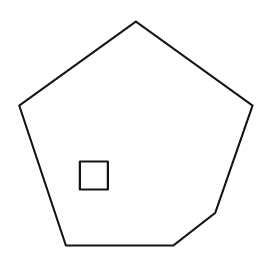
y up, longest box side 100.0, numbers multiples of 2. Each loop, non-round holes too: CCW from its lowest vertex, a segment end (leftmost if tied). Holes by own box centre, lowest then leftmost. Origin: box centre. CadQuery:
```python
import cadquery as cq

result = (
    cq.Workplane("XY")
    .moveTo(-30.0, -48.0)
    .lineTo(16.0, -48.0)
    .lineTo(34.0, -34.0)
    .lineTo(50.0, 12.0)
    .lineTo(0.0, 48.0)
    .lineTo(-50.0, 12.0)
    .close()
    .moveTo(-24.0, -24.0)
    .lineTo(-12.0, -24.0)
    .lineTo(-12.0, -12.0)
    .lineTo(-24.0, -12.0)
    .close()
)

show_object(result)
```